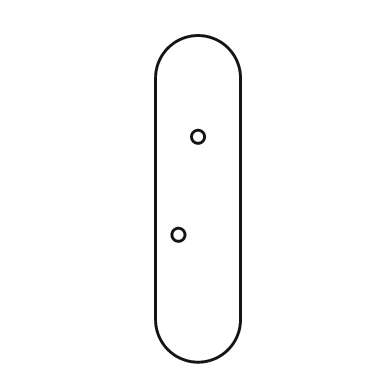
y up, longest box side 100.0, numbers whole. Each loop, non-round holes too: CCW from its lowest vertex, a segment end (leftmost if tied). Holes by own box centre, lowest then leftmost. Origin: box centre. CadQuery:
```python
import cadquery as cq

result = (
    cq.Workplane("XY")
    .moveTo(-13.0, -37.0)
    .threePointArc((0.0, -50.0), (13.0, -37.0))
    .lineTo(13.0, 37.0)
    .threePointArc((0.0, 50.0), (-13.0, 37.0))
    .close()
    .moveTo(-6.0, -11.0)
    .circle(2.0)
    .moveTo(0.0, 19.0)
    .circle(2.0)
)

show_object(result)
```